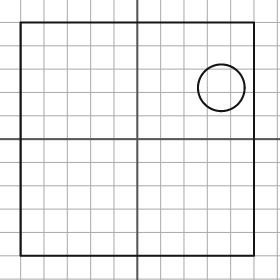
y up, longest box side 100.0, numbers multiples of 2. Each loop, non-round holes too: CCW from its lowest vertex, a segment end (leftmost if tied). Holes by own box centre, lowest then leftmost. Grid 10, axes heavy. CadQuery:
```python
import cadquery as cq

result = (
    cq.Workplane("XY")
    .moveTo(-50.0, -50.0)
    .lineTo(50.0, -50.0)
    .lineTo(50.0, 50.0)
    .lineTo(-50.0, 50.0)
    .close()
    .moveTo(36.0, 22.0)
    .circle(10.0)
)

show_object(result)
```